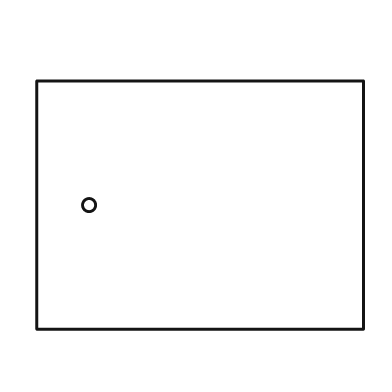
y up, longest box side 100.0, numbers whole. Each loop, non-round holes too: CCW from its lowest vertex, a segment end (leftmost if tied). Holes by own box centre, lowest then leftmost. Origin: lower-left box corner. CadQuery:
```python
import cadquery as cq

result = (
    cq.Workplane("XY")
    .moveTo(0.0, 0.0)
    .lineTo(100.0, 0.0)
    .lineTo(100.0, 76.0)
    .lineTo(0.0, 76.0)
    .close()
    .moveTo(16.0, 38.0)
    .circle(2.0)
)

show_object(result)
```